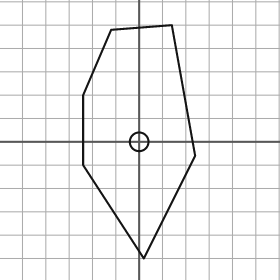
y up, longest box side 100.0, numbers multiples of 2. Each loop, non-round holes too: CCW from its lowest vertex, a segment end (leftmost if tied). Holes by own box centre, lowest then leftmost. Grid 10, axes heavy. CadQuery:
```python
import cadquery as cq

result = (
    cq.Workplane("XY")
    .moveTo(2.0, -50.0)
    .lineTo(24.0, -6.0)
    .lineTo(14.0, 50.0)
    .lineTo(-12.0, 48.0)
    .lineTo(-24.0, 20.0)
    .lineTo(-24.0, -10.0)
    .close()
    .moveTo(0.0, 0.0)
    .circle(4.0)
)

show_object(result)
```